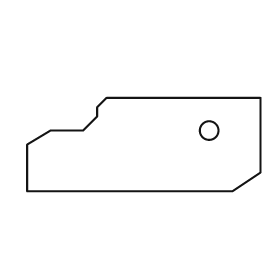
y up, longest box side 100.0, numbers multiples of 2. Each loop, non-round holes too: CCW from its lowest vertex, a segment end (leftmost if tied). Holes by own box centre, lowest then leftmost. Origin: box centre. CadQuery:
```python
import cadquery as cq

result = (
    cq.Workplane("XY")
    .moveTo(-50.0, -20.0)
    .lineTo(38.0, -20.0)
    .lineTo(50.0, -12.0)
    .lineTo(50.0, 20.0)
    .lineTo(-16.0, 20.0)
    .lineTo(-20.0, 16.0)
    .lineTo(-20.0, 12.0)
    .lineTo(-26.0, 6.0)
    .lineTo(-40.0, 6.0)
    .lineTo(-50.0, 0.0)
    .close()
    .moveTo(28.0, 6.0)
    .circle(4.0)
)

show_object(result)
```